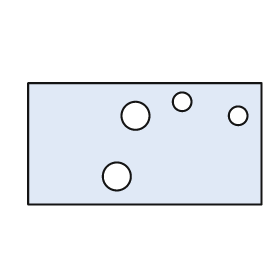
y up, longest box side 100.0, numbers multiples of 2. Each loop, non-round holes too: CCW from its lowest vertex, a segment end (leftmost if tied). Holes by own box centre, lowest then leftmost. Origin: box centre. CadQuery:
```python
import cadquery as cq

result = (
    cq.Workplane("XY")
    .moveTo(-50.0, -26.0)
    .lineTo(50.0, -26.0)
    .lineTo(50.0, 26.0)
    .lineTo(-50.0, 26.0)
    .close()
    .moveTo(-12.0, -14.0)
    .circle(6.0)
    .moveTo(-4.0, 12.0)
    .circle(6.0)
    .moveTo(40.0, 12.0)
    .circle(4.0)
    .moveTo(16.0, 18.0)
    .circle(4.0)
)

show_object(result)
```